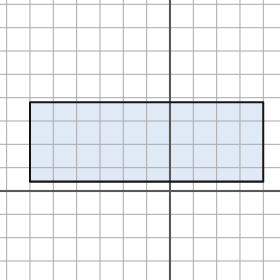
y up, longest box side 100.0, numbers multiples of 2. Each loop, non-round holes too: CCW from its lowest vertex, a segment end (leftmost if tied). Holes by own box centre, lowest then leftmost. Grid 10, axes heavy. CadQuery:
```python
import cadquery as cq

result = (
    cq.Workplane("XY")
    .moveTo(-60.0, 4.0)
    .lineTo(40.0, 4.0)
    .lineTo(40.0, 38.0)
    .lineTo(-60.0, 38.0)
    .close()
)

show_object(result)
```